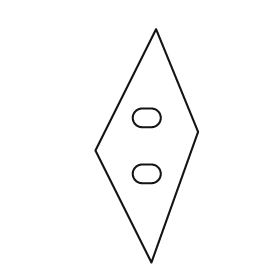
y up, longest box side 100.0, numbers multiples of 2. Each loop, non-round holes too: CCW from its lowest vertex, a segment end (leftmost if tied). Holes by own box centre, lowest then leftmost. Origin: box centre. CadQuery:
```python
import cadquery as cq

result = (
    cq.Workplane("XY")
    .moveTo(2.0, -50.0)
    .lineTo(22.0, 6.0)
    .lineTo(4.0, 50.0)
    .lineTo(-22.0, -2.0)
    .close()
    .moveTo(-2.0, -16.0)
    .lineTo(2.0, -16.0)
    .threePointArc((6.0, -12.0), (2.0, -8.0))
    .lineTo(-2.0, -8.0)
    .threePointArc((-6.0, -12.0), (-2.0, -16.0))
    .close()
    .moveTo(-2.0, 8.0)
    .lineTo(2.0, 8.0)
    .threePointArc((6.0, 12.0), (2.0, 16.0))
    .lineTo(-2.0, 16.0)
    .threePointArc((-6.0, 12.0), (-2.0, 8.0))
    .close()
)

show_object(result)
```